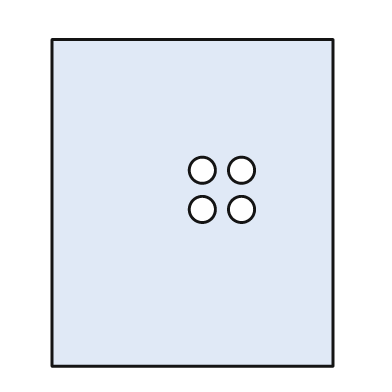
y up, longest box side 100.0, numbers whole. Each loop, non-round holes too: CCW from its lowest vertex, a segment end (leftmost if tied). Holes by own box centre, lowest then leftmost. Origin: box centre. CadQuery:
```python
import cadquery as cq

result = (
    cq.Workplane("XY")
    .moveTo(-43.0, -50.0)
    .lineTo(43.0, -50.0)
    .lineTo(43.0, 50.0)
    .lineTo(-43.0, 50.0)
    .close()
    .moveTo(3.0, -2.0)
    .circle(4.0)
    .moveTo(15.0, -2.0)
    .circle(4.0)
    .moveTo(3.0, 10.0)
    .circle(4.0)
    .moveTo(15.0, 10.0)
    .circle(4.0)
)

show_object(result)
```